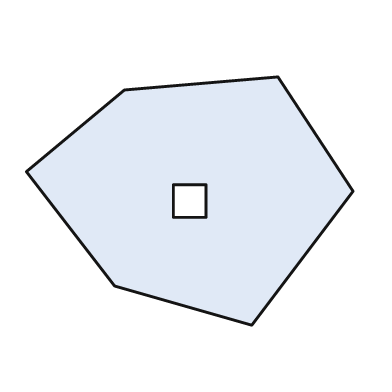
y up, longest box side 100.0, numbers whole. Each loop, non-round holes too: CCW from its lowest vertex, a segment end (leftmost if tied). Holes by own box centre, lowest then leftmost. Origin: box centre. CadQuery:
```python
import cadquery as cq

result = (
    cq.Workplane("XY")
    .moveTo(19.0, -38.0)
    .lineTo(50.0, 3.0)
    .lineTo(27.0, 38.0)
    .lineTo(-20.0, 34.0)
    .lineTo(-50.0, 9.0)
    .lineTo(-23.0, -26.0)
    .close()
    .moveTo(-5.0, -5.0)
    .lineTo(5.0, -5.0)
    .lineTo(5.0, 5.0)
    .lineTo(-5.0, 5.0)
    .close()
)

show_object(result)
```